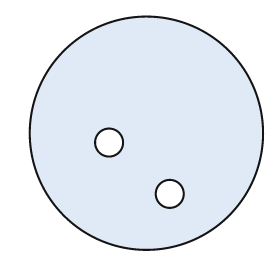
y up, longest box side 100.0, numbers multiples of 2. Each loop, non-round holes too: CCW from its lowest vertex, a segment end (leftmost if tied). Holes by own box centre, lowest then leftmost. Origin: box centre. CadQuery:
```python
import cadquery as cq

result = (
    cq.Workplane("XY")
    .moveTo(0.0, 0.0)
    .circle(50.0)
    .moveTo(10.0, -26.0)
    .circle(6.0)
    .moveTo(-16.0, -4.0)
    .circle(6.0)
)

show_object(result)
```